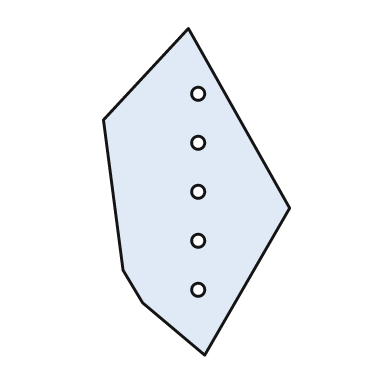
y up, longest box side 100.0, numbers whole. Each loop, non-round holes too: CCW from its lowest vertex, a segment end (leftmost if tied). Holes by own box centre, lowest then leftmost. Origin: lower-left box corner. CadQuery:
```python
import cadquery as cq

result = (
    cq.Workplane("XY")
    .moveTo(31.0, 0.0)
    .lineTo(57.0, 45.0)
    .lineTo(26.0, 100.0)
    .lineTo(0.0, 72.0)
    .lineTo(6.0, 26.0)
    .lineTo(12.0, 16.0)
    .close()
    .moveTo(29.0, 20.0)
    .circle(2.0)
    .moveTo(29.0, 35.0)
    .circle(2.0)
    .moveTo(29.0, 50.0)
    .circle(2.0)
    .moveTo(29.0, 65.0)
    .circle(2.0)
    .moveTo(29.0, 80.0)
    .circle(2.0)
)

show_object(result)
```